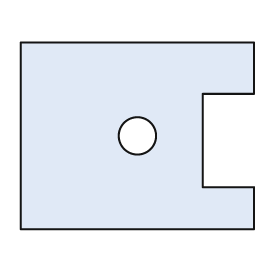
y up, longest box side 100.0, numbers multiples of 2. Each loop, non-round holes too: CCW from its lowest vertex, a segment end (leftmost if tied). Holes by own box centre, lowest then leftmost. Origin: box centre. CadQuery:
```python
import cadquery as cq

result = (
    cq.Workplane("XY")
    .moveTo(-50.0, -40.0)
    .lineTo(50.0, -40.0)
    .lineTo(50.0, -22.0)
    .lineTo(28.0, -22.0)
    .lineTo(28.0, 18.0)
    .lineTo(50.0, 18.0)
    .lineTo(50.0, 40.0)
    .lineTo(-50.0, 40.0)
    .close()
    .moveTo(0.0, 0.0)
    .circle(8.0)
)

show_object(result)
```